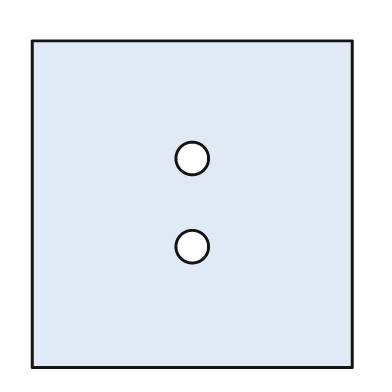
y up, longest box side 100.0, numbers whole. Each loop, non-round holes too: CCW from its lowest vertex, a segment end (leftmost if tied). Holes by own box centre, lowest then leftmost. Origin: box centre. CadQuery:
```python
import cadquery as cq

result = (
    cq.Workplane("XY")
    .moveTo(-49.0, -50.0)
    .lineTo(49.0, -50.0)
    .lineTo(49.0, 50.0)
    .lineTo(-49.0, 50.0)
    .close()
    .moveTo(0.0, -13.0)
    .circle(5.0)
    .moveTo(0.0, 14.0)
    .circle(5.0)
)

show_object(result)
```